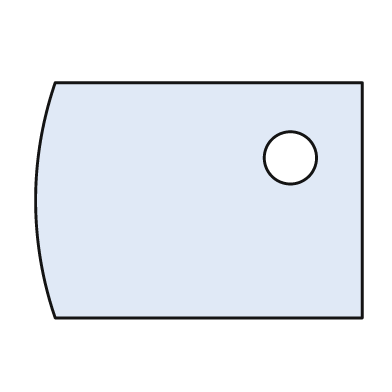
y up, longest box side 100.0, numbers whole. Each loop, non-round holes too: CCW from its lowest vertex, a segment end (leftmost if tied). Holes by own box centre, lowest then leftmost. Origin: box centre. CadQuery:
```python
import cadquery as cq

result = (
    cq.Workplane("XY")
    .moveTo(-44.0, -36.0)
    .lineTo(50.0, -36.0)
    .lineTo(50.0, 36.0)
    .lineTo(-44.0, 36.0)
    .threePointArc((-50.0, 0.0), (-44.0, -36.0))
    .close()
    .moveTo(28.0, 13.0)
    .circle(8.0)
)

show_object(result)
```